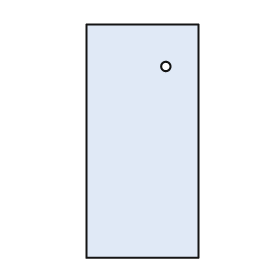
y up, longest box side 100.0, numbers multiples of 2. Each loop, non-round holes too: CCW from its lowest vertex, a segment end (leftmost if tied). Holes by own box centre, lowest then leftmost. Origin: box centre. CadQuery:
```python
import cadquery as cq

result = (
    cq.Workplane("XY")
    .moveTo(-24.0, -50.0)
    .lineTo(24.0, -50.0)
    .lineTo(24.0, 50.0)
    .lineTo(-24.0, 50.0)
    .close()
    .moveTo(10.0, 32.0)
    .circle(2.0)
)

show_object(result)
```